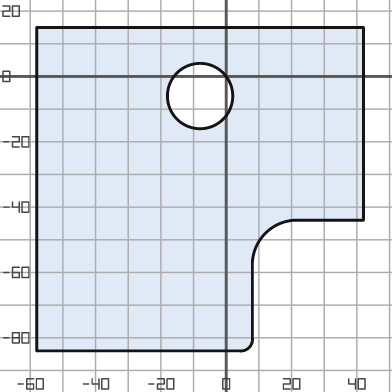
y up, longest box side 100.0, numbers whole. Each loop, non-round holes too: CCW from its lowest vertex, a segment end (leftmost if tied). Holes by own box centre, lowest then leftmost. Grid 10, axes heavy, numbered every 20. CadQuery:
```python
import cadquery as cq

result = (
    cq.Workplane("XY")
    .moveTo(-58.0, -84.0)
    .lineTo(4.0, -84.0)
    .threePointArc((7.0, -83.0), (8.0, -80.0))
    .lineTo(8.0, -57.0)
    .threePointArc((12.0, -48.0), (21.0, -44.0))
    .lineTo(42.0, -44.0)
    .lineTo(42.0, 15.0)
    .lineTo(-58.0, 15.0)
    .close()
    .moveTo(-8.0, -6.0)
    .circle(10.0)
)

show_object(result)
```